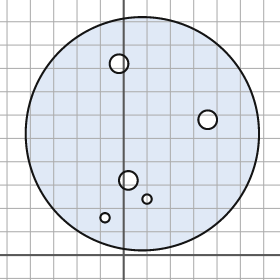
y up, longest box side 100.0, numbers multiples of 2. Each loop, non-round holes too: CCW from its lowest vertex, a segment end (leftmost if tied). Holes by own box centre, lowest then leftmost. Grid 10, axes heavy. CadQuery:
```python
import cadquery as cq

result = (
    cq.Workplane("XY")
    .moveTo(8.0, 52.0)
    .circle(50.0)
    .moveTo(-8.0, 16.0)
    .circle(2.0)
    .moveTo(10.0, 24.0)
    .circle(2.0)
    .moveTo(2.0, 32.0)
    .circle(4.0)
    .moveTo(36.0, 58.0)
    .circle(4.0)
    .moveTo(-2.0, 82.0)
    .circle(4.0)
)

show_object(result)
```